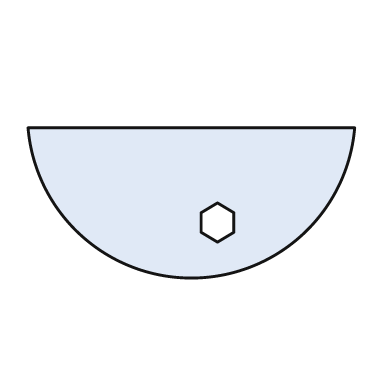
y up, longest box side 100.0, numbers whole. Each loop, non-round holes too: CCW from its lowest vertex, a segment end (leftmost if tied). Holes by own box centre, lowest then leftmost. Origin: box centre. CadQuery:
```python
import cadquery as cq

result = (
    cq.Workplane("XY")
    .moveTo(-50.0, 23.0)
    .threePointArc((0.0, -23.0), (50.0, 23.0))
    .close()
    .moveTo(8.0, -12.0)
    .lineTo(13.0, -9.0)
    .lineTo(13.0, -3.0)
    .lineTo(8.0, 0.0)
    .lineTo(3.0, -3.0)
    .lineTo(3.0, -9.0)
    .close()
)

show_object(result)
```